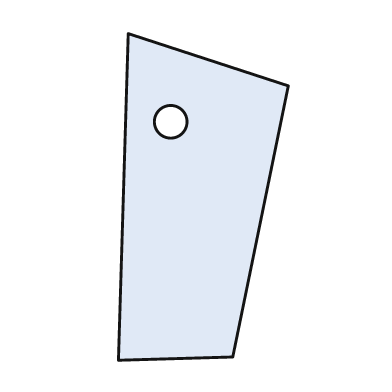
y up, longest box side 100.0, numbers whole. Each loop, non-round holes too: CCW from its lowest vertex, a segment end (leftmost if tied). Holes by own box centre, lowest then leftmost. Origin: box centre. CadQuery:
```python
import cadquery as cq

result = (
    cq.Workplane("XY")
    .moveTo(-26.0, -50.0)
    .lineTo(9.0, -49.0)
    .lineTo(26.0, 34.0)
    .lineTo(-23.0, 50.0)
    .close()
    .moveTo(-10.0, 23.0)
    .circle(5.0)
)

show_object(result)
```